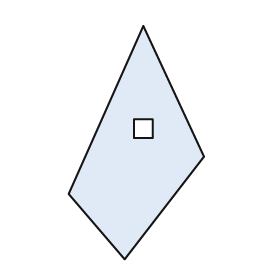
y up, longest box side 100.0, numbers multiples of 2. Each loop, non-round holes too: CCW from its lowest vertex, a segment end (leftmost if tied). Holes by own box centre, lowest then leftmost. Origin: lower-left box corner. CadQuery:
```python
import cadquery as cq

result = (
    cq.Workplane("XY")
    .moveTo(24.0, 0.0)
    .lineTo(58.0, 44.0)
    .lineTo(32.0, 100.0)
    .lineTo(0.0, 28.0)
    .close()
    .moveTo(28.0, 52.0)
    .lineTo(36.0, 52.0)
    .lineTo(36.0, 60.0)
    .lineTo(28.0, 60.0)
    .close()
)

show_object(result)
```